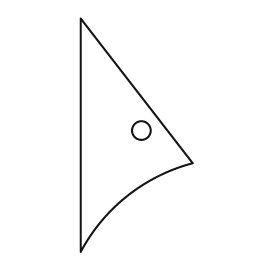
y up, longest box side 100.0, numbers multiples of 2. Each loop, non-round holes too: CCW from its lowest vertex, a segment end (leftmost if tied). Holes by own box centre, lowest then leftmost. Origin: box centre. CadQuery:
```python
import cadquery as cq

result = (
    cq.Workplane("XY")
    .moveTo(-24.0, -50.0)
    .threePointArc((-4.0, -26.0), (24.0, -12.0))
    .lineTo(-24.0, 50.0)
    .close()
    .moveTo(2.0, 2.0)
    .circle(4.0)
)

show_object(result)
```